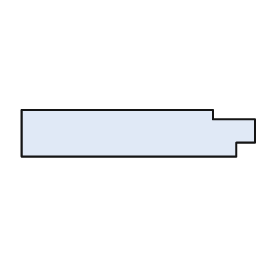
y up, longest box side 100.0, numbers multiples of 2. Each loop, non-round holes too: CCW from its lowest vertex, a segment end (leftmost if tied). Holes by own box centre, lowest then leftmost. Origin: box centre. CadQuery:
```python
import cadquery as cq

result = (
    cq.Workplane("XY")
    .moveTo(-50.0, -10.0)
    .lineTo(42.0, -10.0)
    .lineTo(42.0, -4.0)
    .lineTo(50.0, -4.0)
    .lineTo(50.0, 6.0)
    .lineTo(32.0, 6.0)
    .lineTo(32.0, 10.0)
    .lineTo(-50.0, 10.0)
    .close()
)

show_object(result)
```